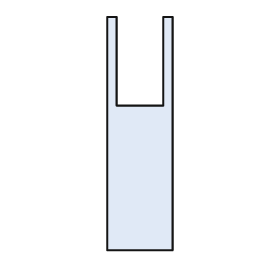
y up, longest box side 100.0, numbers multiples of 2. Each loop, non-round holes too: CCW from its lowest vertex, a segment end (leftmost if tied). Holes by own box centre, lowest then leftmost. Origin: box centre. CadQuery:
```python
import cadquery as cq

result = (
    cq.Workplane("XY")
    .moveTo(-14.0, -50.0)
    .lineTo(14.0, -50.0)
    .lineTo(14.0, 50.0)
    .lineTo(10.0, 50.0)
    .lineTo(10.0, 12.0)
    .lineTo(-10.0, 12.0)
    .lineTo(-10.0, 50.0)
    .lineTo(-14.0, 50.0)
    .close()
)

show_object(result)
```